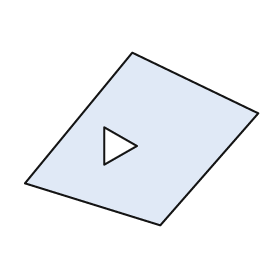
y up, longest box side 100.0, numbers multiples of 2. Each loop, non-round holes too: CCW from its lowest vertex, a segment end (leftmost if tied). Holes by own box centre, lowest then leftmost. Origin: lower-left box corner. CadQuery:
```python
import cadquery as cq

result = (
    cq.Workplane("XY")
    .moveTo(58.0, 0.0)
    .lineTo(100.0, 48.0)
    .lineTo(46.0, 74.0)
    .lineTo(0.0, 18.0)
    .close()
    .moveTo(34.0, 26.0)
    .lineTo(48.0, 34.0)
    .lineTo(34.0, 42.0)
    .close()
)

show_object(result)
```